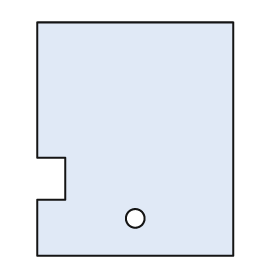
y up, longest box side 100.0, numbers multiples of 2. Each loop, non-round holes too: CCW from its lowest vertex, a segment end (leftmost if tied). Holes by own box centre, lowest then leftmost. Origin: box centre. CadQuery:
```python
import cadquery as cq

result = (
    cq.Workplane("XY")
    .moveTo(-42.0, -50.0)
    .lineTo(42.0, -50.0)
    .lineTo(42.0, 50.0)
    .lineTo(-42.0, 50.0)
    .lineTo(-42.0, -8.0)
    .lineTo(-30.0, -8.0)
    .lineTo(-30.0, -26.0)
    .lineTo(-42.0, -26.0)
    .close()
    .moveTo(0.0, -34.0)
    .circle(4.0)
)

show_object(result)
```